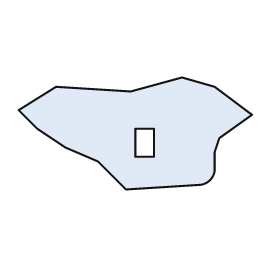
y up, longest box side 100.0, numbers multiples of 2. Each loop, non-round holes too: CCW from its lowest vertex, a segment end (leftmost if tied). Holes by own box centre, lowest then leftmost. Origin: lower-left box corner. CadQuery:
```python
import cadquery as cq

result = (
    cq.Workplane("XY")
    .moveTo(46.0, 0.0)
    .lineTo(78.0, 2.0)
    .threePointArc((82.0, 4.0), (84.0, 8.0))
    .lineTo(84.0, 16.0)
    .lineTo(86.0, 22.0)
    .lineTo(100.0, 32.0)
    .lineTo(84.0, 44.0)
    .lineTo(70.0, 48.0)
    .lineTo(48.0, 42.0)
    .lineTo(16.0, 44.0)
    .lineTo(0.0, 34.0)
    .lineTo(8.0, 26.0)
    .lineTo(20.0, 18.0)
    .lineTo(34.0, 12.0)
    .close()
    .moveTo(50.0, 14.0)
    .lineTo(58.0, 14.0)
    .lineTo(58.0, 26.0)
    .lineTo(50.0, 26.0)
    .close()
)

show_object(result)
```